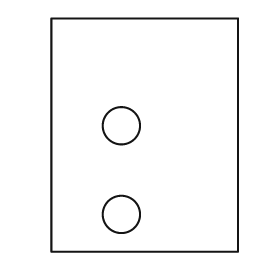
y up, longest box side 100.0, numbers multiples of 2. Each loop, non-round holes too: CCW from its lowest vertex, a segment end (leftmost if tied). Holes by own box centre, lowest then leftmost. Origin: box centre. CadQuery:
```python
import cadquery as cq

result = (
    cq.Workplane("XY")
    .moveTo(-40.0, -50.0)
    .lineTo(40.0, -50.0)
    .lineTo(40.0, 50.0)
    .lineTo(-40.0, 50.0)
    .close()
    .moveTo(-10.0, -34.0)
    .circle(8.0)
    .moveTo(-10.0, 4.0)
    .circle(8.0)
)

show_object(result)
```